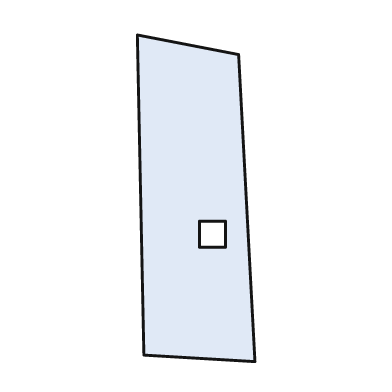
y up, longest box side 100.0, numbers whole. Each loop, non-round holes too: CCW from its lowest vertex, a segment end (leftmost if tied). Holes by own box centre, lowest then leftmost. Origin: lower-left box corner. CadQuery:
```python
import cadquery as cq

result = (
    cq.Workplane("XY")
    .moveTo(36.0, 0.0)
    .lineTo(31.0, 94.0)
    .lineTo(0.0, 100.0)
    .lineTo(2.0, 2.0)
    .close()
    .moveTo(19.0, 35.0)
    .lineTo(27.0, 35.0)
    .lineTo(27.0, 43.0)
    .lineTo(19.0, 43.0)
    .close()
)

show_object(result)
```